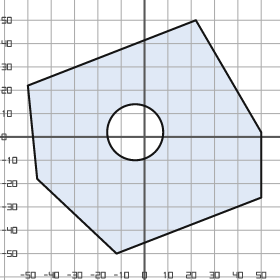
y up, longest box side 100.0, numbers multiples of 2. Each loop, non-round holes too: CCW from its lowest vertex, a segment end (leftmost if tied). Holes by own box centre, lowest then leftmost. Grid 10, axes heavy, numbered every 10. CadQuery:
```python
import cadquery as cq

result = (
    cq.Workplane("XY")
    .moveTo(-12.0, -50.0)
    .lineTo(50.0, -26.0)
    .lineTo(50.0, 2.0)
    .lineTo(22.0, 50.0)
    .lineTo(-50.0, 22.0)
    .lineTo(-46.0, -18.0)
    .close()
    .moveTo(-4.0, 2.0)
    .circle(12.0)
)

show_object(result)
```